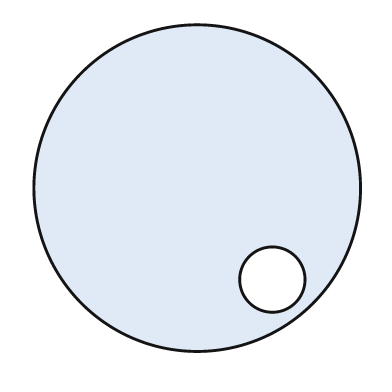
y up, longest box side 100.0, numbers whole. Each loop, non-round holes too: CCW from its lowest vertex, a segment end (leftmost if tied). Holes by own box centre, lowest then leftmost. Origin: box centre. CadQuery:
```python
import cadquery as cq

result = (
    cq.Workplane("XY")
    .moveTo(0.0, 0.0)
    .circle(50.0)
    .moveTo(23.0, -28.0)
    .circle(10.0)
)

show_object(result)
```